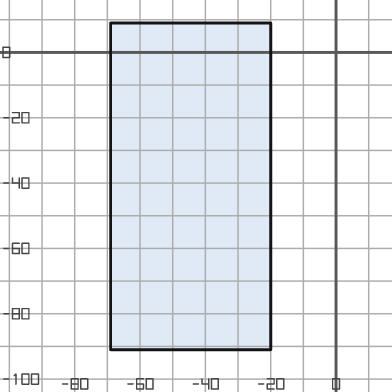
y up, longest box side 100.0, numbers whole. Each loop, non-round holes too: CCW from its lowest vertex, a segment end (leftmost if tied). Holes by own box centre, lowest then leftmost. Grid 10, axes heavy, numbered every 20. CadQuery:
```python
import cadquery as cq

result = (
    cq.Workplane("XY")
    .moveTo(-69.0, -91.0)
    .lineTo(-20.0, -91.0)
    .lineTo(-20.0, 9.0)
    .lineTo(-69.0, 9.0)
    .close()
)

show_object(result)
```